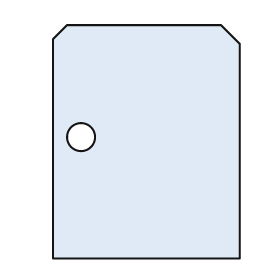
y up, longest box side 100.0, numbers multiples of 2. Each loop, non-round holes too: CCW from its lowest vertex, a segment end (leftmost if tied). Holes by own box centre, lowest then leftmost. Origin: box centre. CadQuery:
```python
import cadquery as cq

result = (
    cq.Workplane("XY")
    .moveTo(-40.0, -50.0)
    .lineTo(40.0, -50.0)
    .lineTo(40.0, 42.0)
    .lineTo(32.0, 50.0)
    .lineTo(-34.0, 50.0)
    .lineTo(-40.0, 44.0)
    .close()
    .moveTo(-28.0, 2.0)
    .circle(6.0)
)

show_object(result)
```